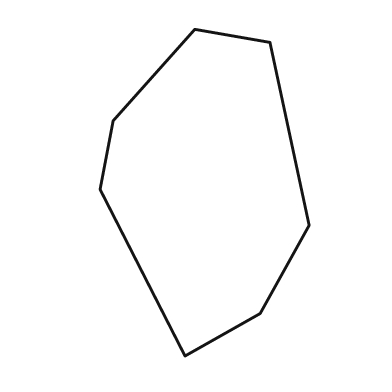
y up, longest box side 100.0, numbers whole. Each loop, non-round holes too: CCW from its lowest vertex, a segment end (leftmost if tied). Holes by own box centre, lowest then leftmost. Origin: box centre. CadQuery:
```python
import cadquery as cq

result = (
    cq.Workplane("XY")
    .moveTo(-6.0, -50.0)
    .lineTo(17.0, -37.0)
    .lineTo(32.0, -10.0)
    .lineTo(20.0, 46.0)
    .lineTo(-3.0, 50.0)
    .lineTo(-28.0, 22.0)
    .lineTo(-32.0, 1.0)
    .close()
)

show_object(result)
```